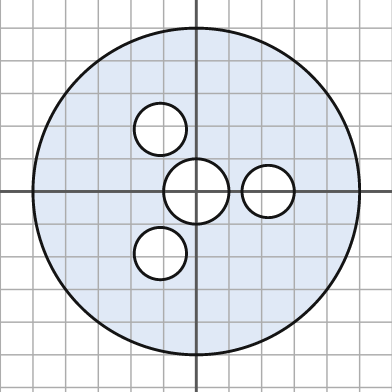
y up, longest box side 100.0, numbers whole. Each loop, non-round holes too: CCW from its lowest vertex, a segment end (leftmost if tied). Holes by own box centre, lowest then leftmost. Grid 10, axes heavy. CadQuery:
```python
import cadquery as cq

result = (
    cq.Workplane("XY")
    .moveTo(0.0, 0.0)
    .circle(50.0)
    .moveTo(-11.0, -19.0)
    .circle(8.0)
    .moveTo(0.0, 0.0)
    .circle(10.0)
    .moveTo(22.0, 0.0)
    .circle(8.0)
    .moveTo(-11.0, 19.0)
    .circle(8.0)
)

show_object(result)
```